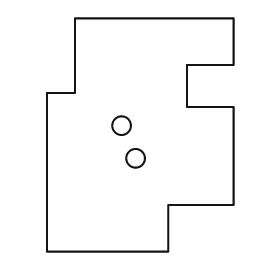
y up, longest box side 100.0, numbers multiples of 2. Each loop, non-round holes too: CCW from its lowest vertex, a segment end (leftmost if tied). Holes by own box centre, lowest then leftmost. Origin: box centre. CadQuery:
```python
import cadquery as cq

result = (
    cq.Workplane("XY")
    .moveTo(-40.0, -50.0)
    .lineTo(12.0, -50.0)
    .lineTo(12.0, -30.0)
    .lineTo(40.0, -30.0)
    .lineTo(40.0, 12.0)
    .lineTo(20.0, 12.0)
    .lineTo(20.0, 30.0)
    .lineTo(40.0, 30.0)
    .lineTo(40.0, 50.0)
    .lineTo(-28.0, 50.0)
    .lineTo(-28.0, 18.0)
    .lineTo(-40.0, 18.0)
    .close()
    .moveTo(-2.0, -10.0)
    .circle(4.0)
    .moveTo(-8.0, 4.0)
    .circle(4.0)
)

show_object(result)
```